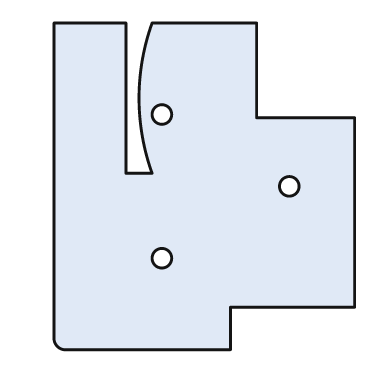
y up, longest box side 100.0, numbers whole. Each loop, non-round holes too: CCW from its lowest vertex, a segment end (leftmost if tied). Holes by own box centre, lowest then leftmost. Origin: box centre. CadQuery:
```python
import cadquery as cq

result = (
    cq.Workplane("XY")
    .moveTo(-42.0, -50.0)
    .lineTo(8.0, -50.0)
    .lineTo(8.0, -37.0)
    .lineTo(46.0, -37.0)
    .lineTo(46.0, 21.0)
    .lineTo(16.0, 21.0)
    .lineTo(16.0, 50.0)
    .lineTo(-16.0, 50.0)
    .threePointArc((-20.0, 27.0), (-16.0, 4.0))
    .lineTo(-24.0, 4.0)
    .lineTo(-24.0, 50.0)
    .lineTo(-46.0, 50.0)
    .lineTo(-46.0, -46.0)
    .threePointArc((-45.0, -49.0), (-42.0, -50.0))
    .close()
    .moveTo(-13.0, -22.0)
    .circle(3.0)
    .moveTo(26.0, 0.0)
    .circle(3.0)
    .moveTo(-13.0, 22.0)
    .circle(3.0)
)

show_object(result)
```